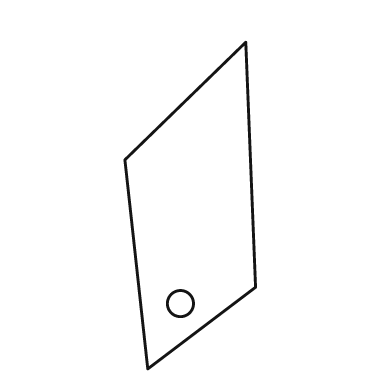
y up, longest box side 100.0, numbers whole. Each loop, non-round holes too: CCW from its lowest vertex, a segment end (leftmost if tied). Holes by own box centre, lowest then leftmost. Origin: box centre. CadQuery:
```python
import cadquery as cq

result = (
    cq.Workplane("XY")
    .moveTo(-13.0, -50.0)
    .lineTo(20.0, -25.0)
    .lineTo(17.0, 50.0)
    .lineTo(-20.0, 14.0)
    .close()
    .moveTo(-3.0, -30.0)
    .circle(4.0)
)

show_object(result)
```